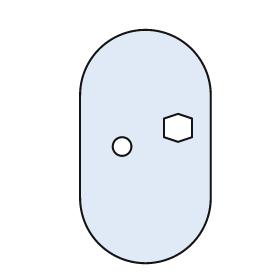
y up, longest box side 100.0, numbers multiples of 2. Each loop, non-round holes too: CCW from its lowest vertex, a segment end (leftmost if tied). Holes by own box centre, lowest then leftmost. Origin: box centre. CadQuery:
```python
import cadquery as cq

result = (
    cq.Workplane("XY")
    .moveTo(-28.0, -22.0)
    .threePointArc((0.0, -50.0), (28.0, -22.0))
    .lineTo(28.0, 22.0)
    .threePointArc((0.0, 50.0), (-28.0, 22.0))
    .close()
    .moveTo(-10.0, 0.0)
    .circle(4.0)
    .moveTo(14.0, 2.0)
    .lineTo(20.0, 4.0)
    .lineTo(20.0, 12.0)
    .lineTo(14.0, 14.0)
    .lineTo(8.0, 12.0)
    .lineTo(8.0, 4.0)
    .close()
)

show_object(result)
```